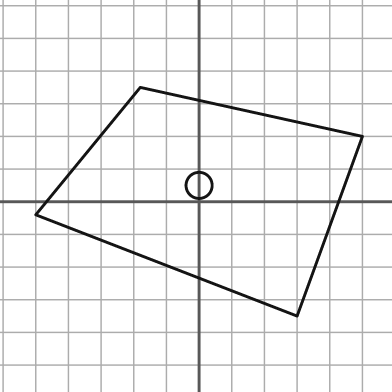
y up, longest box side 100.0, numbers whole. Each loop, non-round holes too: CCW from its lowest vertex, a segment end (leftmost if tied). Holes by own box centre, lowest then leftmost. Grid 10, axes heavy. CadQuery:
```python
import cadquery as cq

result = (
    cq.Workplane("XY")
    .moveTo(30.0, -35.0)
    .lineTo(50.0, 20.0)
    .lineTo(-18.0, 35.0)
    .lineTo(-50.0, -4.0)
    .close()
    .moveTo(0.0, 5.0)
    .circle(4.0)
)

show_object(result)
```